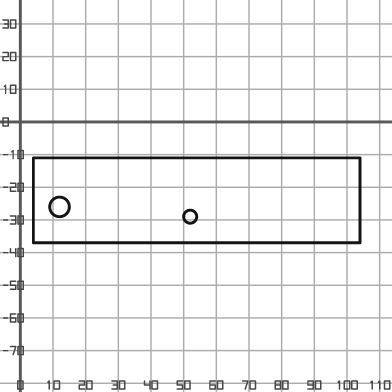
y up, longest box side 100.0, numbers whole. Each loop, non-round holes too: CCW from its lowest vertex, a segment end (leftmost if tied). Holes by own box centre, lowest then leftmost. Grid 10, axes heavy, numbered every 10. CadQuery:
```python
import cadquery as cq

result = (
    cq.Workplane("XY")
    .moveTo(4.0, -37.0)
    .lineTo(104.0, -37.0)
    .lineTo(104.0, -11.0)
    .lineTo(4.0, -11.0)
    .close()
    .moveTo(52.0, -29.0)
    .circle(2.0)
    .moveTo(12.0, -26.0)
    .circle(3.0)
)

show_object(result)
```